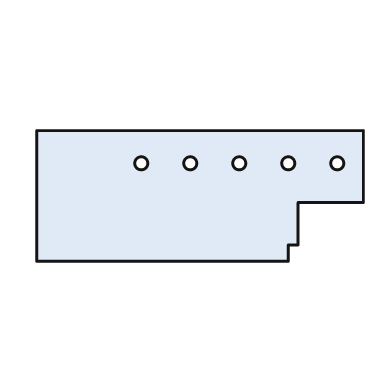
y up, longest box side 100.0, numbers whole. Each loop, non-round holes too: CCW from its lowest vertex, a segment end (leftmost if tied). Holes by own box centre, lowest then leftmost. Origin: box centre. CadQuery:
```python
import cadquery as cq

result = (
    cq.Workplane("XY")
    .moveTo(-50.0, -20.0)
    .lineTo(27.0, -20.0)
    .lineTo(27.0, -15.0)
    .lineTo(30.0, -15.0)
    .lineTo(30.0, -2.0)
    .lineTo(50.0, -2.0)
    .lineTo(50.0, 20.0)
    .lineTo(-50.0, 20.0)
    .close()
    .moveTo(-18.0, 10.0)
    .circle(2.0)
    .moveTo(-3.0, 10.0)
    .circle(2.0)
    .moveTo(12.0, 10.0)
    .circle(2.0)
    .moveTo(27.0, 10.0)
    .circle(2.0)
    .moveTo(42.0, 10.0)
    .circle(2.0)
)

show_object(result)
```